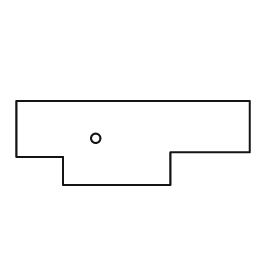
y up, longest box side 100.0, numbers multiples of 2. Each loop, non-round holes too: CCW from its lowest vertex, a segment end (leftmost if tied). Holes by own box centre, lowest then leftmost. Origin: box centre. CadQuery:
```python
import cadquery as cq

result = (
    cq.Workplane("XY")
    .moveTo(-30.0, -18.0)
    .lineTo(16.0, -18.0)
    .lineTo(16.0, -4.0)
    .lineTo(50.0, -4.0)
    .lineTo(50.0, 18.0)
    .lineTo(-50.0, 18.0)
    .lineTo(-50.0, -6.0)
    .lineTo(-30.0, -6.0)
    .close()
    .moveTo(-16.0, 2.0)
    .circle(2.0)
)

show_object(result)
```